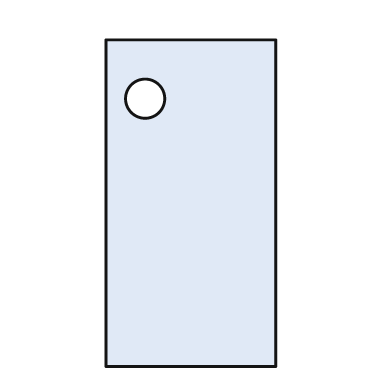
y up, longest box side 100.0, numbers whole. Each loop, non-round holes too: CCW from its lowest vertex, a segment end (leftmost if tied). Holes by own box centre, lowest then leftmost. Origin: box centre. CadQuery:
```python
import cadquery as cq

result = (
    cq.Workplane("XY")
    .moveTo(-26.0, -50.0)
    .lineTo(26.0, -50.0)
    .lineTo(26.0, 50.0)
    .lineTo(-26.0, 50.0)
    .close()
    .moveTo(-14.0, 32.0)
    .circle(6.0)
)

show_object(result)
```